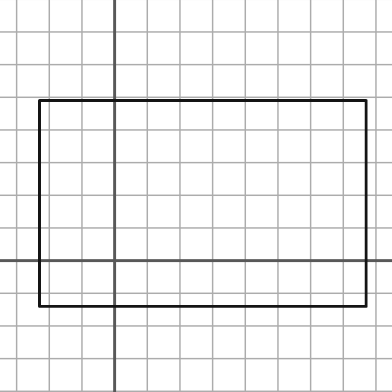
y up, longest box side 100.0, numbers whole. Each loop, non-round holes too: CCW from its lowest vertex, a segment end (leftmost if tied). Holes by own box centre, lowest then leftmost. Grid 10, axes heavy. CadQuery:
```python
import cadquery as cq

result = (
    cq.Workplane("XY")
    .moveTo(-23.0, -14.0)
    .lineTo(77.0, -14.0)
    .lineTo(77.0, 49.0)
    .lineTo(-23.0, 49.0)
    .close()
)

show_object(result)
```